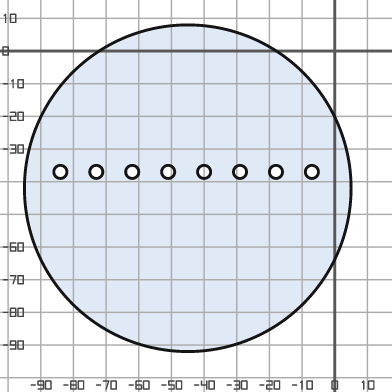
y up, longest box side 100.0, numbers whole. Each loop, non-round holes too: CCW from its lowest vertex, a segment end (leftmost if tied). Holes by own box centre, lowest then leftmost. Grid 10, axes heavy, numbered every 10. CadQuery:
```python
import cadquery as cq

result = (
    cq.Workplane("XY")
    .moveTo(-45.0, -42.0)
    .circle(50.0)
    .moveTo(-84.0, -37.0)
    .circle(2.0)
    .moveTo(-73.0, -37.0)
    .circle(2.0)
    .moveTo(-62.0, -37.0)
    .circle(2.0)
    .moveTo(-51.0, -37.0)
    .circle(2.0)
    .moveTo(-40.0, -37.0)
    .circle(2.0)
    .moveTo(-29.0, -37.0)
    .circle(2.0)
    .moveTo(-18.0, -37.0)
    .circle(2.0)
    .moveTo(-7.0, -37.0)
    .circle(2.0)
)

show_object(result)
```